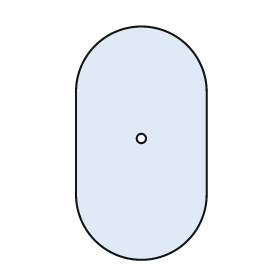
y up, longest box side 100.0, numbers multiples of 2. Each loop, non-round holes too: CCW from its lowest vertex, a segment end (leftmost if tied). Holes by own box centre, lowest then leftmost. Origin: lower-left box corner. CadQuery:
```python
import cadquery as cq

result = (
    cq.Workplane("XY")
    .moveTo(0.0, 28.0)
    .threePointArc((28.0, 0.0), (56.0, 28.0))
    .lineTo(56.0, 72.0)
    .threePointArc((28.0, 100.0), (0.0, 72.0))
    .close()
    .moveTo(28.0, 52.0)
    .circle(2.0)
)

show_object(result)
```